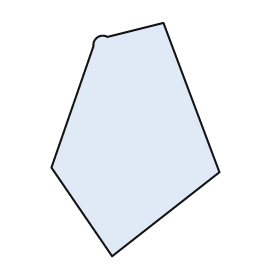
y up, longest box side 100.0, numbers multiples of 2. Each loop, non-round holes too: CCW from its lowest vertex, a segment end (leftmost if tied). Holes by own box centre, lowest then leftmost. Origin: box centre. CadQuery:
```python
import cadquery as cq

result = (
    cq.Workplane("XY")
    .moveTo(-10.0, -50.0)
    .lineTo(36.0, -14.0)
    .lineTo(12.0, 50.0)
    .lineTo(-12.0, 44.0)
    .threePointArc((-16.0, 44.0), (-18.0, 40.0))
    .lineTo(-36.0, -12.0)
    .close()
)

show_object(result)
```